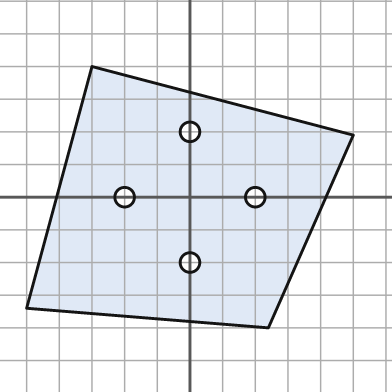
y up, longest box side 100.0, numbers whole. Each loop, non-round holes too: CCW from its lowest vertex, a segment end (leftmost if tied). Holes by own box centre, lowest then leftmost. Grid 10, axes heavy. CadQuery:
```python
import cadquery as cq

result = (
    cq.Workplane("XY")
    .moveTo(24.0, -40.0)
    .lineTo(50.0, 19.0)
    .lineTo(-30.0, 40.0)
    .lineTo(-50.0, -34.0)
    .close()
    .moveTo(0.0, -20.0)
    .circle(3.0)
    .moveTo(-20.0, 0.0)
    .circle(3.0)
    .moveTo(20.0, 0.0)
    .circle(3.0)
    .moveTo(0.0, 20.0)
    .circle(3.0)
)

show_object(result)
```